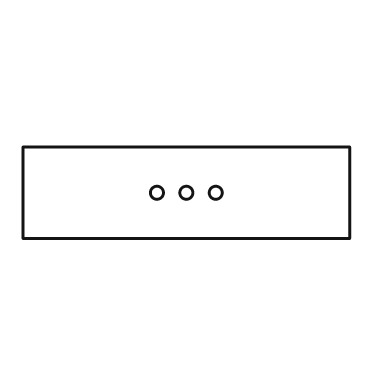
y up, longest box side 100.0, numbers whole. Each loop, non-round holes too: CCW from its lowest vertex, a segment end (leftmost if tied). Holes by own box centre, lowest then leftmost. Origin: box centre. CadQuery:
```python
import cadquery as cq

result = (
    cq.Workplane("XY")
    .moveTo(-50.0, -14.0)
    .lineTo(50.0, -14.0)
    .lineTo(50.0, 14.0)
    .lineTo(-50.0, 14.0)
    .close()
    .moveTo(-9.0, 0.0)
    .circle(2.0)
    .moveTo(0.0, 0.0)
    .circle(2.0)
    .moveTo(9.0, 0.0)
    .circle(2.0)
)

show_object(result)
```